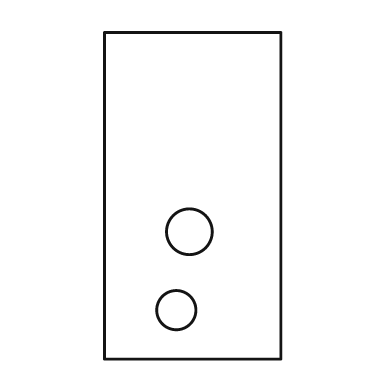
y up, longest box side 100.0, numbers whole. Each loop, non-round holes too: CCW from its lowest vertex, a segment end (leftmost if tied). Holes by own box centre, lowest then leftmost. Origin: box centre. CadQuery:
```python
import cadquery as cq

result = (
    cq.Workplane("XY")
    .moveTo(-27.0, -50.0)
    .lineTo(27.0, -50.0)
    .lineTo(27.0, 50.0)
    .lineTo(-27.0, 50.0)
    .close()
    .moveTo(-5.0, -35.0)
    .circle(6.0)
    .moveTo(-1.0, -11.0)
    .circle(7.0)
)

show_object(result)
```